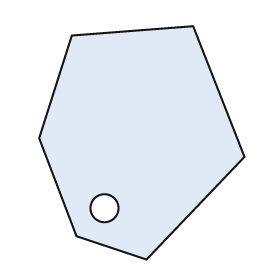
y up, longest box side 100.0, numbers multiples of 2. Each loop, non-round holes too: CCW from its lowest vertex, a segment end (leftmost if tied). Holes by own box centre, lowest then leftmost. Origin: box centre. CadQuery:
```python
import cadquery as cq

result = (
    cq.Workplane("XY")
    .moveTo(2.0, -50.0)
    .lineTo(44.0, -6.0)
    .lineTo(22.0, 50.0)
    .lineTo(-30.0, 46.0)
    .lineTo(-44.0, 2.0)
    .lineTo(-28.0, -40.0)
    .close()
    .moveTo(-16.0, -28.0)
    .circle(6.0)
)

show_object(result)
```